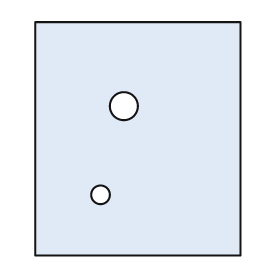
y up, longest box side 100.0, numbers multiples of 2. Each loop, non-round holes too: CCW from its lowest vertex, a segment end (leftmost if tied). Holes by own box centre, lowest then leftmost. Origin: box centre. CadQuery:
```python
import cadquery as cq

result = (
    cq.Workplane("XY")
    .moveTo(-44.0, -50.0)
    .lineTo(44.0, -50.0)
    .lineTo(44.0, 50.0)
    .lineTo(-44.0, 50.0)
    .close()
    .moveTo(-16.0, -24.0)
    .circle(4.0)
    .moveTo(-6.0, 14.0)
    .circle(6.0)
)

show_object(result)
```